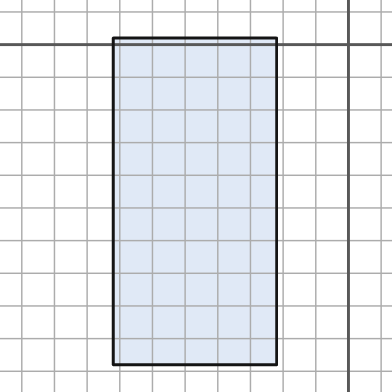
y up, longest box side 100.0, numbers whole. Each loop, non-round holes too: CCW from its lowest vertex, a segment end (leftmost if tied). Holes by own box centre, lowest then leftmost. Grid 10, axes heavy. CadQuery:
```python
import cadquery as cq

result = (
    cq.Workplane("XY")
    .moveTo(-72.0, -98.0)
    .lineTo(-22.0, -98.0)
    .lineTo(-22.0, 2.0)
    .lineTo(-72.0, 2.0)
    .close()
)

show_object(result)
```